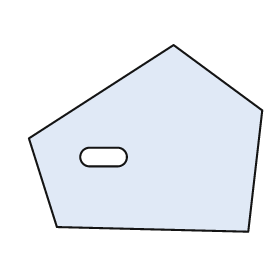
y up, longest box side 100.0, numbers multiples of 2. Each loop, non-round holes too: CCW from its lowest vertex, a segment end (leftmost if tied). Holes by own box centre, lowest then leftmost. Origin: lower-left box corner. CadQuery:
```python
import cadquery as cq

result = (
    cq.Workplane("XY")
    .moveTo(94.0, 0.0)
    .lineTo(100.0, 52.0)
    .lineTo(62.0, 80.0)
    .lineTo(0.0, 40.0)
    .lineTo(12.0, 2.0)
    .close()
    .moveTo(26.0, 28.0)
    .lineTo(38.0, 28.0)
    .threePointArc((42.0, 32.0), (38.0, 36.0))
    .lineTo(26.0, 36.0)
    .threePointArc((22.0, 32.0), (26.0, 28.0))
    .close()
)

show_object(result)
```